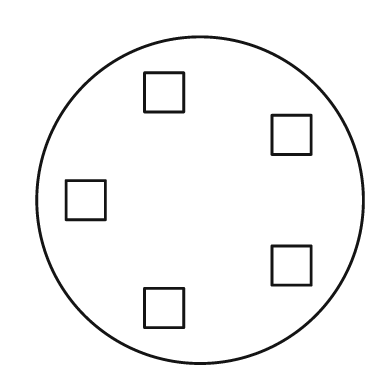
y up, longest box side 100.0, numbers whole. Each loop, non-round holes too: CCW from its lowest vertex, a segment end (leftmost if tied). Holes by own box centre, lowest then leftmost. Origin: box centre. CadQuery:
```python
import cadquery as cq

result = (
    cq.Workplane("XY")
    .moveTo(0.0, 0.0)
    .circle(50.0)
    .moveTo(-17.0, -39.0)
    .lineTo(-5.0, -39.0)
    .lineTo(-5.0, -27.0)
    .lineTo(-17.0, -27.0)
    .close()
    .moveTo(22.0, -26.0)
    .lineTo(34.0, -26.0)
    .lineTo(34.0, -14.0)
    .lineTo(22.0, -14.0)
    .close()
    .moveTo(-41.0, -6.0)
    .lineTo(-29.0, -6.0)
    .lineTo(-29.0, 6.0)
    .lineTo(-41.0, 6.0)
    .close()
    .moveTo(22.0, 14.0)
    .lineTo(34.0, 14.0)
    .lineTo(34.0, 26.0)
    .lineTo(22.0, 26.0)
    .close()
    .moveTo(-17.0, 27.0)
    .lineTo(-5.0, 27.0)
    .lineTo(-5.0, 39.0)
    .lineTo(-17.0, 39.0)
    .close()
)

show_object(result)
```